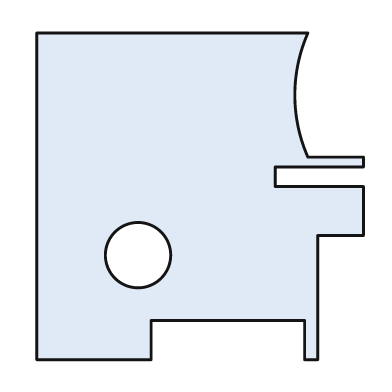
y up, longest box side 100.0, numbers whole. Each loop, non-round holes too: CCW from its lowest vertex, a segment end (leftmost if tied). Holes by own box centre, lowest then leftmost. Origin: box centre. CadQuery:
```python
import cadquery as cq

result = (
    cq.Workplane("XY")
    .moveTo(-50.0, -50.0)
    .lineTo(-15.0, -50.0)
    .lineTo(-15.0, -38.0)
    .lineTo(32.0, -38.0)
    .lineTo(32.0, -50.0)
    .lineTo(36.0, -50.0)
    .lineTo(36.0, -12.0)
    .lineTo(50.0, -12.0)
    .lineTo(50.0, 3.0)
    .lineTo(23.0, 3.0)
    .lineTo(23.0, 9.0)
    .lineTo(50.0, 9.0)
    .lineTo(50.0, 12.0)
    .lineTo(33.0, 12.0)
    .threePointArc((29.0, 31.0), (33.0, 50.0))
    .lineTo(-50.0, 50.0)
    .close()
    .moveTo(-19.0, -18.0)
    .circle(10.0)
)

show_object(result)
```